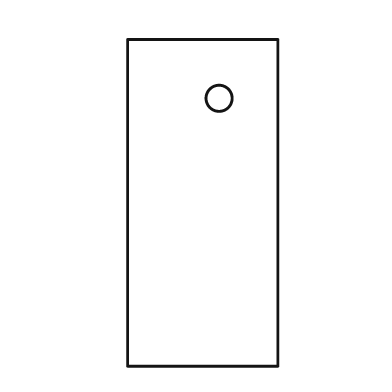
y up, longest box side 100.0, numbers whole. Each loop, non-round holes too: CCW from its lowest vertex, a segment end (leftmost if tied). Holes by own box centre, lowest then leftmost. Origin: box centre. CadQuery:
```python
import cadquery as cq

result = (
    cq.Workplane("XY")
    .moveTo(-23.0, -50.0)
    .lineTo(23.0, -50.0)
    .lineTo(23.0, 50.0)
    .lineTo(-23.0, 50.0)
    .close()
    .moveTo(5.0, 32.0)
    .circle(4.0)
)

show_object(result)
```